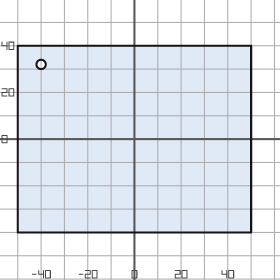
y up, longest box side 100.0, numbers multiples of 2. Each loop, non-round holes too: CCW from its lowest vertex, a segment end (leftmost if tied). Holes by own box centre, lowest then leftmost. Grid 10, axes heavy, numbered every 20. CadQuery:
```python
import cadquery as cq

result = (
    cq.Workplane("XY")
    .moveTo(-50.0, -40.0)
    .lineTo(50.0, -40.0)
    .lineTo(50.0, 40.0)
    .lineTo(-50.0, 40.0)
    .close()
    .moveTo(-40.0, 32.0)
    .circle(2.0)
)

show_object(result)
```